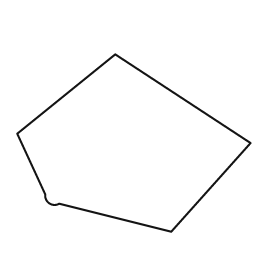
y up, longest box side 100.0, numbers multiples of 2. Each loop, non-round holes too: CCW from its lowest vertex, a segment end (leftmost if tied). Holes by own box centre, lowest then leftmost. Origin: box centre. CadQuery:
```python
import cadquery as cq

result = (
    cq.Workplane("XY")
    .moveTo(16.0, -38.0)
    .lineTo(50.0, 0.0)
    .lineTo(-8.0, 38.0)
    .lineTo(-50.0, 4.0)
    .lineTo(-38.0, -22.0)
    .threePointArc((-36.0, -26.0), (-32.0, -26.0))
    .close()
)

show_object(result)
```